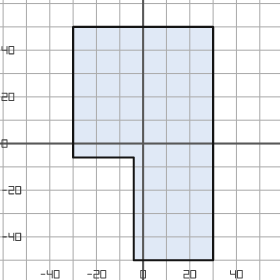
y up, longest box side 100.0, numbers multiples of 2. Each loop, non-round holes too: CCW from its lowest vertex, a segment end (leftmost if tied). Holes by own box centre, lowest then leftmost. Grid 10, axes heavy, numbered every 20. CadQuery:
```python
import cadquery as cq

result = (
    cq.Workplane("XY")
    .moveTo(-4.0, -50.0)
    .lineTo(30.0, -50.0)
    .lineTo(30.0, 50.0)
    .lineTo(-30.0, 50.0)
    .lineTo(-30.0, -6.0)
    .lineTo(-4.0, -6.0)
    .close()
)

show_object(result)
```